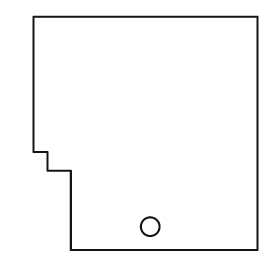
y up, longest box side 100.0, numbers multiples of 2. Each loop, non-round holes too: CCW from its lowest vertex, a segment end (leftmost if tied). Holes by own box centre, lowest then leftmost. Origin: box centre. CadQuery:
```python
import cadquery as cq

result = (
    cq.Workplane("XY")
    .moveTo(-32.0, -50.0)
    .lineTo(48.0, -50.0)
    .lineTo(48.0, 50.0)
    .lineTo(-48.0, 50.0)
    .lineTo(-48.0, -8.0)
    .lineTo(-42.0, -8.0)
    .lineTo(-42.0, -16.0)
    .lineTo(-32.0, -16.0)
    .close()
    .moveTo(2.0, -40.0)
    .circle(4.0)
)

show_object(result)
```